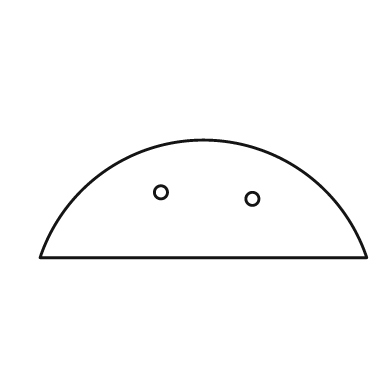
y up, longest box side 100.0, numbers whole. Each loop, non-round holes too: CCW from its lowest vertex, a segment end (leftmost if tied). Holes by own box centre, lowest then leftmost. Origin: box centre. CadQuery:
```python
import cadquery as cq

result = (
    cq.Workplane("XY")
    .moveTo(-50.0, -18.0)
    .lineTo(50.0, -18.0)
    .threePointArc((0.0, 18.0), (-50.0, -18.0))
    .close()
    .moveTo(15.0, 0.0)
    .circle(2.0)
    .moveTo(-13.0, 2.0)
    .circle(2.0)
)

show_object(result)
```